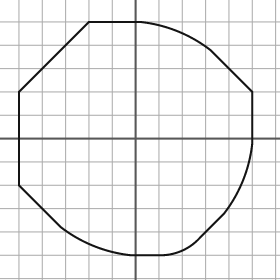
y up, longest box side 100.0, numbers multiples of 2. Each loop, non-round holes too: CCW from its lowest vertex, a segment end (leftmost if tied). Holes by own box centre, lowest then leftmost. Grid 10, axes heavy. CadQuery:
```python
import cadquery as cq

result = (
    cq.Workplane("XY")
    .moveTo(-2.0, -50.0)
    .lineTo(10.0, -50.0)
    .threePointArc((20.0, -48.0), (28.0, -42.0))
    .lineTo(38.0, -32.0)
    .threePointArc((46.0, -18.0), (50.0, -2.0))
    .lineTo(50.0, 20.0)
    .lineTo(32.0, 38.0)
    .threePointArc((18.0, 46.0), (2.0, 50.0))
    .lineTo(-20.0, 50.0)
    .lineTo(-50.0, 20.0)
    .lineTo(-50.0, -20.0)
    .lineTo(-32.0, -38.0)
    .threePointArc((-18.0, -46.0), (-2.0, -50.0))
    .close()
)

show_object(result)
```